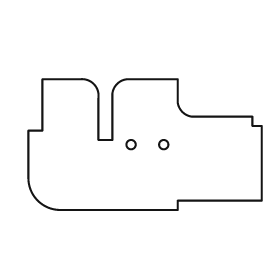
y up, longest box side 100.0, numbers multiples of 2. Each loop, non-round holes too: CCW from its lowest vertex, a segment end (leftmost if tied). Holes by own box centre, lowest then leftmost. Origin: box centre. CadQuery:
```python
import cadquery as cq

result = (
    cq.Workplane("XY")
    .moveTo(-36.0, -28.0)
    .lineTo(14.0, -28.0)
    .lineTo(14.0, -24.0)
    .lineTo(50.0, -24.0)
    .lineTo(50.0, 8.0)
    .lineTo(46.0, 8.0)
    .lineTo(46.0, 12.0)
    .lineTo(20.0, 12.0)
    .threePointArc((16.0, 14.0), (14.0, 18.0))
    .lineTo(14.0, 28.0)
    .lineTo(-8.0, 28.0)
    .threePointArc((-12.0, 26.0), (-14.0, 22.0))
    .lineTo(-14.0, 2.0)
    .lineTo(-20.0, 2.0)
    .lineTo(-20.0, 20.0)
    .threePointArc((-22.0, 26.0), (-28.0, 28.0))
    .lineTo(-44.0, 28.0)
    .lineTo(-44.0, 6.0)
    .lineTo(-50.0, 6.0)
    .lineTo(-50.0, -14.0)
    .threePointArc((-46.0, -24.0), (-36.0, -28.0))
    .close()
    .moveTo(-6.0, 0.0)
    .circle(2.0)
    .moveTo(8.0, 0.0)
    .circle(2.0)
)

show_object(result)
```